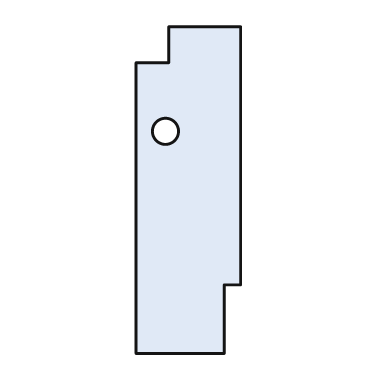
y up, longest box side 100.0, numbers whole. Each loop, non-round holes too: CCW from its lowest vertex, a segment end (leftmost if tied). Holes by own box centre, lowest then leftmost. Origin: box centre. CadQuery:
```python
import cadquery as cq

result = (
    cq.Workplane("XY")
    .moveTo(-16.0, -50.0)
    .lineTo(11.0, -50.0)
    .lineTo(11.0, -29.0)
    .lineTo(16.0, -29.0)
    .lineTo(16.0, 50.0)
    .lineTo(-6.0, 50.0)
    .lineTo(-6.0, 39.0)
    .lineTo(-16.0, 39.0)
    .close()
    .moveTo(-7.0, 18.0)
    .circle(4.0)
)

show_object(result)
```